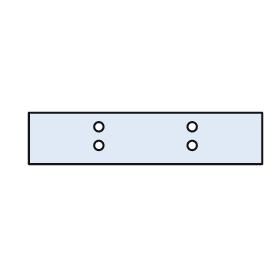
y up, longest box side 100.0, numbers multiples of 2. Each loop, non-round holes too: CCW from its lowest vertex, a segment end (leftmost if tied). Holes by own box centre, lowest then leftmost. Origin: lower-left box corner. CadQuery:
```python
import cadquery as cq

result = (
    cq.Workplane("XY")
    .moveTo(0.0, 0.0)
    .lineTo(100.0, 0.0)
    .lineTo(100.0, 22.0)
    .lineTo(0.0, 22.0)
    .close()
    .moveTo(30.0, 8.0)
    .circle(2.0)
    .moveTo(70.0, 8.0)
    .circle(2.0)
    .moveTo(30.0, 16.0)
    .circle(2.0)
    .moveTo(70.0, 16.0)
    .circle(2.0)
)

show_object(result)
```